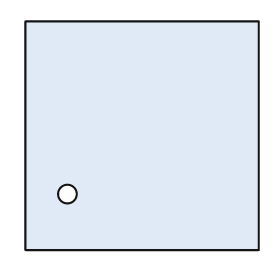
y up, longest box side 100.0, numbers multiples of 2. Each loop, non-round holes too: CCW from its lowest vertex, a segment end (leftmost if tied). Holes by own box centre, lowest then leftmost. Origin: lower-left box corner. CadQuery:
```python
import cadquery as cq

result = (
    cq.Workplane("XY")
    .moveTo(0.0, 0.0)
    .lineTo(100.0, 0.0)
    .lineTo(100.0, 98.0)
    .lineTo(0.0, 98.0)
    .close()
    .moveTo(18.0, 24.0)
    .circle(4.0)
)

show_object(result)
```